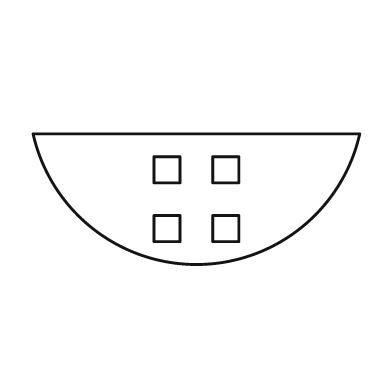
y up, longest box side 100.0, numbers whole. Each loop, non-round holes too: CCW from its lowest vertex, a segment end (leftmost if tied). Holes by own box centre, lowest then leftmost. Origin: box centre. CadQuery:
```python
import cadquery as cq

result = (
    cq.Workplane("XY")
    .moveTo(-50.0, 20.0)
    .threePointArc((0.0, -20.0), (50.0, 20.0))
    .close()
    .moveTo(-13.0, -13.0)
    .lineTo(-5.0, -13.0)
    .lineTo(-5.0, -5.0)
    .lineTo(-13.0, -5.0)
    .close()
    .moveTo(5.0, -13.0)
    .lineTo(13.0, -13.0)
    .lineTo(13.0, -5.0)
    .lineTo(5.0, -5.0)
    .close()
    .moveTo(-13.0, 5.0)
    .lineTo(-5.0, 5.0)
    .lineTo(-5.0, 13.0)
    .lineTo(-13.0, 13.0)
    .close()
    .moveTo(5.0, 5.0)
    .lineTo(13.0, 5.0)
    .lineTo(13.0, 13.0)
    .lineTo(5.0, 13.0)
    .close()
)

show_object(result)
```